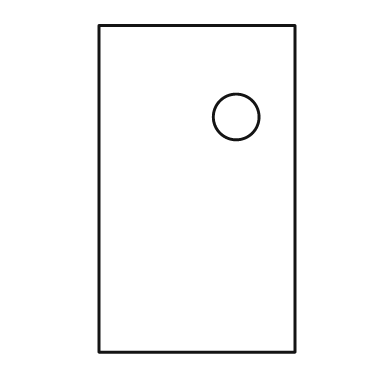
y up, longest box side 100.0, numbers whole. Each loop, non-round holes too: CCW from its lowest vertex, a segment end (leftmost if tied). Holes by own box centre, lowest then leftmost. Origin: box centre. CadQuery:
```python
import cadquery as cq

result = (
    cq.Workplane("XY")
    .moveTo(-30.0, -50.0)
    .lineTo(30.0, -50.0)
    .lineTo(30.0, 50.0)
    .lineTo(-30.0, 50.0)
    .close()
    .moveTo(12.0, 22.0)
    .circle(7.0)
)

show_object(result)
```